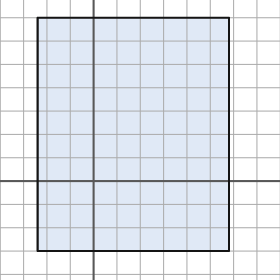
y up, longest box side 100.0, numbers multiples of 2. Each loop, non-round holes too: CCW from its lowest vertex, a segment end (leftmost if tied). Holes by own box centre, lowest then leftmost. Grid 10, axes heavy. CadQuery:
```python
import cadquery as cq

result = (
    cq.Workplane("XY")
    .moveTo(-24.0, -30.0)
    .lineTo(58.0, -30.0)
    .lineTo(58.0, 70.0)
    .lineTo(-24.0, 70.0)
    .close()
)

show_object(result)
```